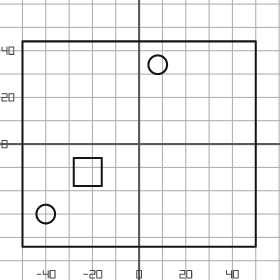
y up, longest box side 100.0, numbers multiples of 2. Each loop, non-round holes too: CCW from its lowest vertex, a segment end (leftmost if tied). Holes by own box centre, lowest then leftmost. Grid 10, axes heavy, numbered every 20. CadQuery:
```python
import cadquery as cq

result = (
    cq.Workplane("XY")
    .moveTo(-50.0, -44.0)
    .lineTo(50.0, -44.0)
    .lineTo(50.0, 44.0)
    .lineTo(-50.0, 44.0)
    .close()
    .moveTo(-40.0, -30.0)
    .circle(4.0)
    .moveTo(-28.0, -18.0)
    .lineTo(-16.0, -18.0)
    .lineTo(-16.0, -6.0)
    .lineTo(-28.0, -6.0)
    .close()
    .moveTo(8.0, 34.0)
    .circle(4.0)
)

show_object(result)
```